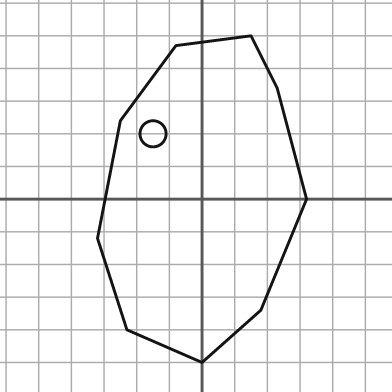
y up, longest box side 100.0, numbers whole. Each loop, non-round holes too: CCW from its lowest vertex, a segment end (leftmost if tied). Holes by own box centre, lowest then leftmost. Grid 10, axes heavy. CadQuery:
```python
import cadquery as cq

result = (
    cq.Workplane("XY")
    .moveTo(0.0, -50.0)
    .lineTo(18.0, -34.0)
    .lineTo(32.0, 0.0)
    .lineTo(23.0, 34.0)
    .lineTo(15.0, 50.0)
    .lineTo(-8.0, 47.0)
    .lineTo(-25.0, 24.0)
    .lineTo(-32.0, -12.0)
    .lineTo(-23.0, -40.0)
    .close()
    .moveTo(-15.0, 20.0)
    .circle(4.0)
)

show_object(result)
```